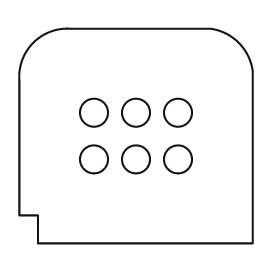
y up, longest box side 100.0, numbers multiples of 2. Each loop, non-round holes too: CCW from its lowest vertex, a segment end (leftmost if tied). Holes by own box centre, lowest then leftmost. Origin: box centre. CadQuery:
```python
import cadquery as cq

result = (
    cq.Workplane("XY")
    .moveTo(-42.0, -46.0)
    .lineTo(50.0, -46.0)
    .lineTo(50.0, 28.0)
    .threePointArc((44.0, 40.0), (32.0, 46.0))
    .lineTo(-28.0, 46.0)
    .threePointArc((-44.0, 40.0), (-50.0, 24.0))
    .lineTo(-50.0, -34.0)
    .lineTo(-42.0, -34.0)
    .close()
    .moveTo(-18.0, -10.0)
    .circle(6.0)
    .moveTo(0.0, -10.0)
    .circle(6.0)
    .moveTo(18.0, -10.0)
    .circle(6.0)
    .moveTo(-18.0, 10.0)
    .circle(6.0)
    .moveTo(0.0, 10.0)
    .circle(6.0)
    .moveTo(18.0, 10.0)
    .circle(6.0)
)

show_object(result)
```